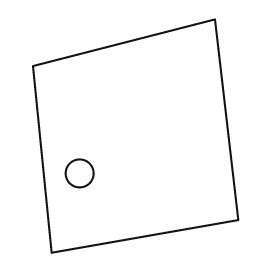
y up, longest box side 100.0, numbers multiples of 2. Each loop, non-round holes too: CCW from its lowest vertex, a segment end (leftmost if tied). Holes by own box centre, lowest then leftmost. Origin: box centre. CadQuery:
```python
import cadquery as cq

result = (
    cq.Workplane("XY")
    .moveTo(-36.0, -50.0)
    .lineTo(44.0, -36.0)
    .lineTo(34.0, 50.0)
    .lineTo(-44.0, 30.0)
    .close()
    .moveTo(-24.0, -16.0)
    .circle(6.0)
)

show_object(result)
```